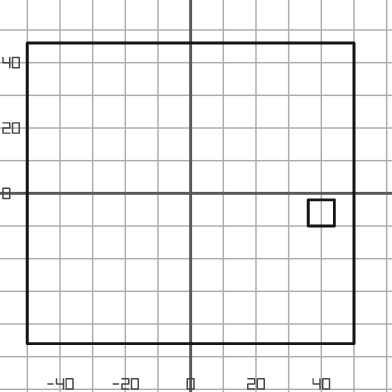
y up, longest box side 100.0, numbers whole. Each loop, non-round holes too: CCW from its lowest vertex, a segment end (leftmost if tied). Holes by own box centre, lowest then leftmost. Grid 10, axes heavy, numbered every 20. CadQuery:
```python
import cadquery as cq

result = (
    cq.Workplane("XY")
    .moveTo(-50.0, -46.0)
    .lineTo(50.0, -46.0)
    .lineTo(50.0, 46.0)
    .lineTo(-50.0, 46.0)
    .close()
    .moveTo(36.0, -10.0)
    .lineTo(44.0, -10.0)
    .lineTo(44.0, -2.0)
    .lineTo(36.0, -2.0)
    .close()
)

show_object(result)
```